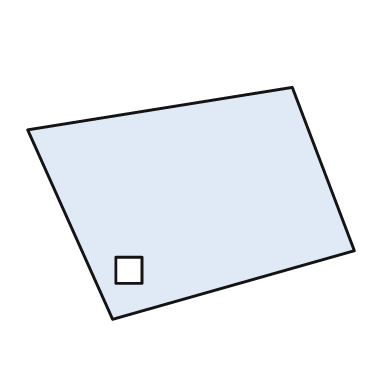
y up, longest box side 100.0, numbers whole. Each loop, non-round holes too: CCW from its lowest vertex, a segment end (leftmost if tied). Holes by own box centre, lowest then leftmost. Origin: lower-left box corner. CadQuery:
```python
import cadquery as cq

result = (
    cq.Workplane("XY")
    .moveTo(26.0, 0.0)
    .lineTo(100.0, 21.0)
    .lineTo(81.0, 71.0)
    .lineTo(0.0, 58.0)
    .close()
    .moveTo(27.0, 11.0)
    .lineTo(35.0, 11.0)
    .lineTo(35.0, 19.0)
    .lineTo(27.0, 19.0)
    .close()
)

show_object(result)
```